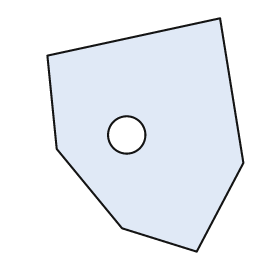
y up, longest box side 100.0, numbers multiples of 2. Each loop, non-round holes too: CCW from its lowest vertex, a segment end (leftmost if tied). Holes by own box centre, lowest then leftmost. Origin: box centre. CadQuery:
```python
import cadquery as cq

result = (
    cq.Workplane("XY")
    .moveTo(22.0, -50.0)
    .lineTo(42.0, -12.0)
    .lineTo(32.0, 50.0)
    .lineTo(-42.0, 34.0)
    .lineTo(-38.0, -6.0)
    .lineTo(-10.0, -40.0)
    .close()
    .moveTo(-8.0, 0.0)
    .circle(8.0)
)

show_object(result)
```